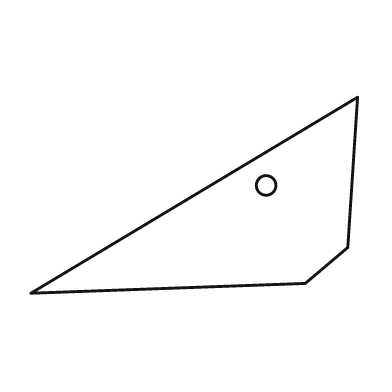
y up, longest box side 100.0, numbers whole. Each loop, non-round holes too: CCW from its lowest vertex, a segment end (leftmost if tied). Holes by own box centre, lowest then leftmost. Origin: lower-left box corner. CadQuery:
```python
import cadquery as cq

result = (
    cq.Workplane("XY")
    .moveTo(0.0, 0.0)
    .lineTo(84.0, 3.0)
    .lineTo(97.0, 14.0)
    .lineTo(100.0, 60.0)
    .close()
    .moveTo(72.0, 33.0)
    .circle(3.0)
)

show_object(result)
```